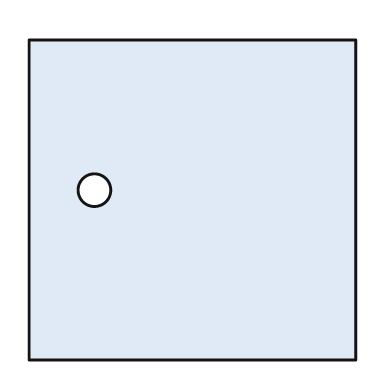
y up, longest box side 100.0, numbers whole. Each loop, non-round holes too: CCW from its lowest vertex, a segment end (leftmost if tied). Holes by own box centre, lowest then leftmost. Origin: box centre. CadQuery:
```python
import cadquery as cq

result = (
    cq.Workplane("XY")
    .moveTo(-50.0, -49.0)
    .lineTo(50.0, -49.0)
    .lineTo(50.0, 49.0)
    .lineTo(-50.0, 49.0)
    .close()
    .moveTo(-30.0, 3.0)
    .circle(5.0)
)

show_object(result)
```